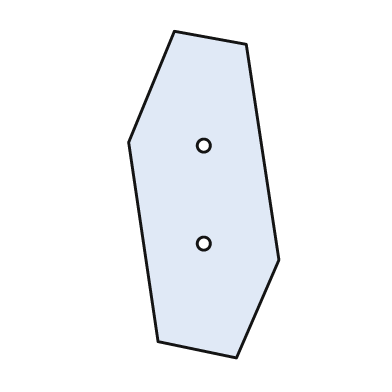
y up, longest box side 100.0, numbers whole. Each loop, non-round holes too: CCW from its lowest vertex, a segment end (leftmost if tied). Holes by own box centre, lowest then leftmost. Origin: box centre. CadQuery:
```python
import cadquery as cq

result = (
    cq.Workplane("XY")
    .moveTo(10.0, -50.0)
    .lineTo(23.0, -20.0)
    .lineTo(13.0, 46.0)
    .lineTo(-9.0, 50.0)
    .lineTo(-23.0, 16.0)
    .lineTo(-14.0, -45.0)
    .close()
    .moveTo(0.0, -15.0)
    .circle(2.0)
    .moveTo(0.0, 15.0)
    .circle(2.0)
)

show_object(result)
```